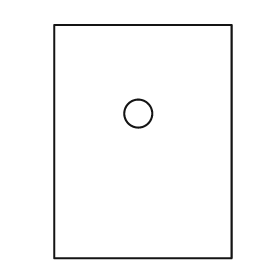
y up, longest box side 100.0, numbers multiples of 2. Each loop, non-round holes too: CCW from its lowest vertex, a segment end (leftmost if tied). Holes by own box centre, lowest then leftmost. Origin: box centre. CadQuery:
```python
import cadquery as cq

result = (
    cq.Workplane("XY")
    .moveTo(-38.0, -50.0)
    .lineTo(38.0, -50.0)
    .lineTo(38.0, 50.0)
    .lineTo(-38.0, 50.0)
    .close()
    .moveTo(-2.0, 12.0)
    .circle(6.0)
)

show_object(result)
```